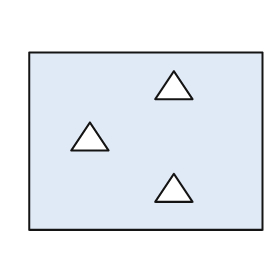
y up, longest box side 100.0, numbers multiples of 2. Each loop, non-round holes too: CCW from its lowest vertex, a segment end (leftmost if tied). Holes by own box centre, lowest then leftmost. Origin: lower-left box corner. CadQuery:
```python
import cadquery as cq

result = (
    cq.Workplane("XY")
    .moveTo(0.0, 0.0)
    .lineTo(100.0, 0.0)
    .lineTo(100.0, 76.0)
    .lineTo(0.0, 76.0)
    .close()
    .moveTo(54.0, 12.0)
    .lineTo(70.0, 12.0)
    .lineTo(62.0, 24.0)
    .close()
    .moveTo(18.0, 34.0)
    .lineTo(34.0, 34.0)
    .lineTo(26.0, 46.0)
    .close()
    .moveTo(54.0, 56.0)
    .lineTo(70.0, 56.0)
    .lineTo(62.0, 68.0)
    .close()
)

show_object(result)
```